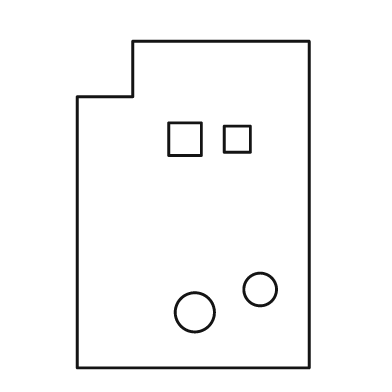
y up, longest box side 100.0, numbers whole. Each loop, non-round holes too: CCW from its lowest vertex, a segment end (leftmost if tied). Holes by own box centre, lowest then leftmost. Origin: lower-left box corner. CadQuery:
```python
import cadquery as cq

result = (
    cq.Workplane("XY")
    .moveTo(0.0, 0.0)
    .lineTo(71.0, 0.0)
    .lineTo(71.0, 100.0)
    .lineTo(17.0, 100.0)
    .lineTo(17.0, 83.0)
    .lineTo(0.0, 83.0)
    .close()
    .moveTo(36.0, 17.0)
    .circle(6.0)
    .moveTo(56.0, 24.0)
    .circle(5.0)
    .moveTo(28.0, 65.0)
    .lineTo(38.0, 65.0)
    .lineTo(38.0, 75.0)
    .lineTo(28.0, 75.0)
    .close()
    .moveTo(45.0, 66.0)
    .lineTo(53.0, 66.0)
    .lineTo(53.0, 74.0)
    .lineTo(45.0, 74.0)
    .close()
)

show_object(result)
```